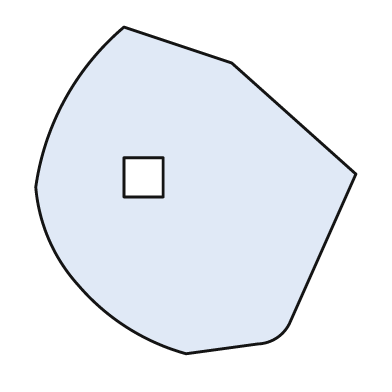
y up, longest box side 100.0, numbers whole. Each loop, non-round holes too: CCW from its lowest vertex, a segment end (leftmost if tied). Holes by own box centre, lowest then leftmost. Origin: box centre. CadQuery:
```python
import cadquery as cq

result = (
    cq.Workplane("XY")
    .moveTo(-3.0, -50.0)
    .lineTo(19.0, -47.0)
    .threePointArc((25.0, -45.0), (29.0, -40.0))
    .lineTo(49.0, 5.0)
    .lineTo(11.0, 39.0)
    .lineTo(-22.0, 50.0)
    .threePointArc((-40.0, 28.0), (-49.0, 1.0))
    .threePointArc((-45.0, -15.0), (-36.0, -29.0))
    .threePointArc((-21.0, -42.0), (-3.0, -50.0))
    .close()
    .moveTo(-22.0, -2.0)
    .lineTo(-10.0, -2.0)
    .lineTo(-10.0, 10.0)
    .lineTo(-22.0, 10.0)
    .close()
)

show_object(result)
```